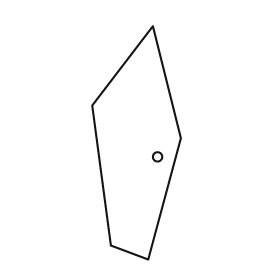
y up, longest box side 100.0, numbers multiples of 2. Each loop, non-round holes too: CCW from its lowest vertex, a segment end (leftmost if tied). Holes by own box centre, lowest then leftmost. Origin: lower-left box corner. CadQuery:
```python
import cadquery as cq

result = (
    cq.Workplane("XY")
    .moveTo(24.0, 0.0)
    .lineTo(38.0, 52.0)
    .lineTo(26.0, 100.0)
    .lineTo(0.0, 66.0)
    .lineTo(8.0, 6.0)
    .close()
    .moveTo(28.0, 44.0)
    .circle(2.0)
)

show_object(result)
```